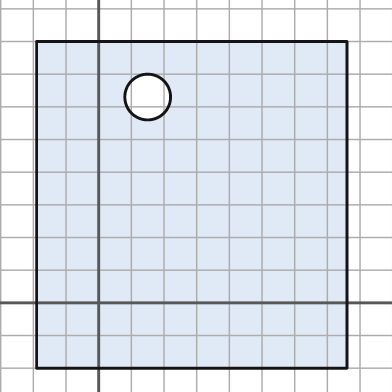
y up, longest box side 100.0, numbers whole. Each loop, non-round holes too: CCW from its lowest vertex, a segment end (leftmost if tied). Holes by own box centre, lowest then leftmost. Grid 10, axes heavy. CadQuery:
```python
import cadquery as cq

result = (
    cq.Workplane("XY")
    .moveTo(-19.0, -20.0)
    .lineTo(76.0, -20.0)
    .lineTo(76.0, 80.0)
    .lineTo(-19.0, 80.0)
    .close()
    .moveTo(15.0, 63.0)
    .circle(7.0)
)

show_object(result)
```